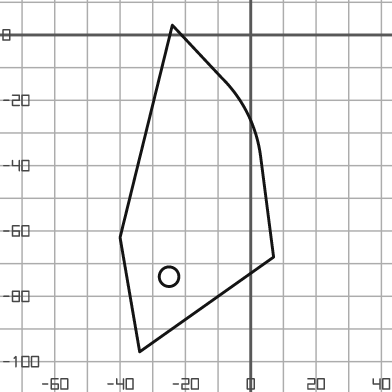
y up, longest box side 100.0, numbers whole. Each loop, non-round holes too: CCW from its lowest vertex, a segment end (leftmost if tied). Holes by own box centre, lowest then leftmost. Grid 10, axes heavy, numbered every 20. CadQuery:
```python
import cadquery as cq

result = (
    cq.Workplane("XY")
    .moveTo(-34.0, -97.0)
    .lineTo(7.0, -68.0)
    .lineTo(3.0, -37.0)
    .threePointArc((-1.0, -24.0), (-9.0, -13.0))
    .lineTo(-24.0, 3.0)
    .lineTo(-40.0, -62.0)
    .close()
    .moveTo(-25.0, -74.0)
    .circle(3.0)
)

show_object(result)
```